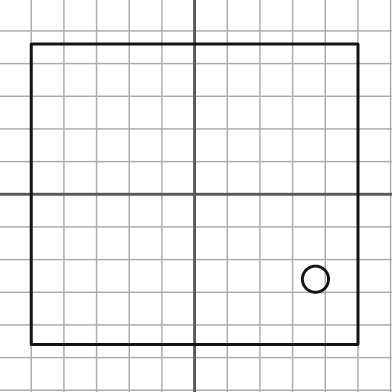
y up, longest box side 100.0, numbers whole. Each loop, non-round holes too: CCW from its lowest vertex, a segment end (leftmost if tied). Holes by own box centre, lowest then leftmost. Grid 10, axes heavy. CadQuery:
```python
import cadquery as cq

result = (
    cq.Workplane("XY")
    .moveTo(-50.0, -46.0)
    .lineTo(50.0, -46.0)
    .lineTo(50.0, 46.0)
    .lineTo(-50.0, 46.0)
    .close()
    .moveTo(37.0, -26.0)
    .circle(4.0)
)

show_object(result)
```